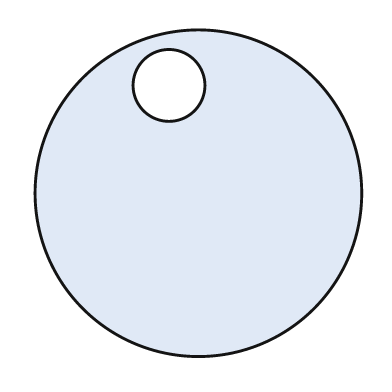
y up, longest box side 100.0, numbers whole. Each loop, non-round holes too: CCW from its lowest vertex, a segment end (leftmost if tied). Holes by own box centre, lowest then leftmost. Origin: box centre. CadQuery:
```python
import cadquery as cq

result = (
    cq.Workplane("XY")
    .moveTo(0.0, 0.0)
    .circle(50.0)
    .moveTo(-9.0, 33.0)
    .circle(11.0)
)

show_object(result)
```